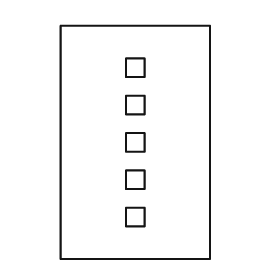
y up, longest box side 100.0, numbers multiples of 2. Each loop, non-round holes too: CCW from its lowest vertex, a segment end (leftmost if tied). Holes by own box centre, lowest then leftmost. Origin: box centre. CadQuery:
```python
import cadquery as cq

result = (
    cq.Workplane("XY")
    .moveTo(-32.0, -50.0)
    .lineTo(32.0, -50.0)
    .lineTo(32.0, 50.0)
    .lineTo(-32.0, 50.0)
    .close()
    .moveTo(-4.0, -36.0)
    .lineTo(4.0, -36.0)
    .lineTo(4.0, -28.0)
    .lineTo(-4.0, -28.0)
    .close()
    .moveTo(-4.0, -20.0)
    .lineTo(4.0, -20.0)
    .lineTo(4.0, -12.0)
    .lineTo(-4.0, -12.0)
    .close()
    .moveTo(-4.0, -4.0)
    .lineTo(4.0, -4.0)
    .lineTo(4.0, 4.0)
    .lineTo(-4.0, 4.0)
    .close()
    .moveTo(-4.0, 12.0)
    .lineTo(4.0, 12.0)
    .lineTo(4.0, 20.0)
    .lineTo(-4.0, 20.0)
    .close()
    .moveTo(-4.0, 28.0)
    .lineTo(4.0, 28.0)
    .lineTo(4.0, 36.0)
    .lineTo(-4.0, 36.0)
    .close()
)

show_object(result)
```